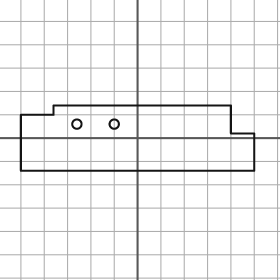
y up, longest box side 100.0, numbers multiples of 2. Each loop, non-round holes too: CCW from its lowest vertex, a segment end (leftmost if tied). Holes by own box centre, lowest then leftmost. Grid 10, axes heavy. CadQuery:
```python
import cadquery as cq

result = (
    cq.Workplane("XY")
    .moveTo(-50.0, -14.0)
    .lineTo(50.0, -14.0)
    .lineTo(50.0, 2.0)
    .lineTo(40.0, 2.0)
    .lineTo(40.0, 14.0)
    .lineTo(-36.0, 14.0)
    .lineTo(-36.0, 10.0)
    .lineTo(-50.0, 10.0)
    .close()
    .moveTo(-26.0, 6.0)
    .circle(2.0)
    .moveTo(-10.0, 6.0)
    .circle(2.0)
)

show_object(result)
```